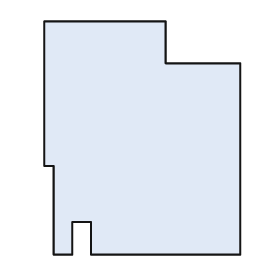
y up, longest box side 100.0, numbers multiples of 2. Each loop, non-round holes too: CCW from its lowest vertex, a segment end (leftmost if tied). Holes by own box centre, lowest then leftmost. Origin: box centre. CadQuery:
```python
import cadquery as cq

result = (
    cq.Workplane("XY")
    .moveTo(-38.0, -50.0)
    .lineTo(-30.0, -50.0)
    .lineTo(-30.0, -36.0)
    .lineTo(-22.0, -36.0)
    .lineTo(-22.0, -50.0)
    .lineTo(42.0, -50.0)
    .lineTo(42.0, 32.0)
    .lineTo(10.0, 32.0)
    .lineTo(10.0, 50.0)
    .lineTo(-42.0, 50.0)
    .lineTo(-42.0, -12.0)
    .lineTo(-38.0, -12.0)
    .close()
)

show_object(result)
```